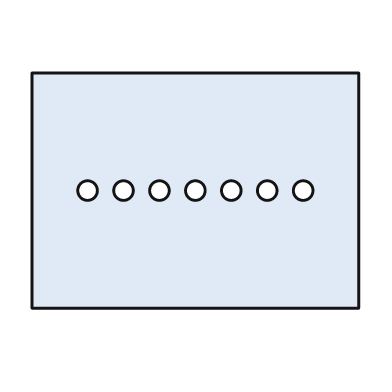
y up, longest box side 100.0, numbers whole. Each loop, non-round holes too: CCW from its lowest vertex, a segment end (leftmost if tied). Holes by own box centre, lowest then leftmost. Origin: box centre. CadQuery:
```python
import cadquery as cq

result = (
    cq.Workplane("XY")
    .moveTo(-50.0, -36.0)
    .lineTo(50.0, -36.0)
    .lineTo(50.0, 36.0)
    .lineTo(-50.0, 36.0)
    .close()
    .moveTo(-33.0, 0.0)
    .circle(3.0)
    .moveTo(-22.0, 0.0)
    .circle(3.0)
    .moveTo(-11.0, 0.0)
    .circle(3.0)
    .moveTo(0.0, 0.0)
    .circle(3.0)
    .moveTo(11.0, 0.0)
    .circle(3.0)
    .moveTo(22.0, 0.0)
    .circle(3.0)
    .moveTo(33.0, 0.0)
    .circle(3.0)
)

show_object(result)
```